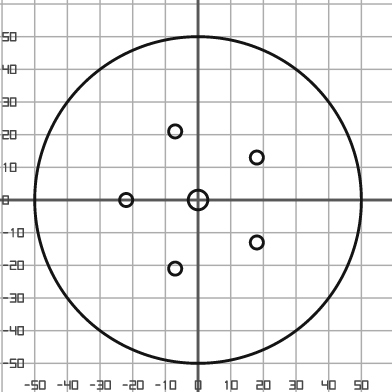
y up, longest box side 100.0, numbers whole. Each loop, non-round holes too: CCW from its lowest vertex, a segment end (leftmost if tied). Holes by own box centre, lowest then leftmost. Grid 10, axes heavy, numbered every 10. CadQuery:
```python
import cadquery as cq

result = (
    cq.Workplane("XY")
    .moveTo(0.0, 0.0)
    .circle(50.0)
    .moveTo(-7.0, -21.0)
    .circle(2.0)
    .moveTo(18.0, -13.0)
    .circle(2.0)
    .moveTo(-22.0, 0.0)
    .circle(2.0)
    .moveTo(0.0, 0.0)
    .circle(3.0)
    .moveTo(18.0, 13.0)
    .circle(2.0)
    .moveTo(-7.0, 21.0)
    .circle(2.0)
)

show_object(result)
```